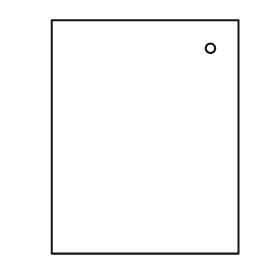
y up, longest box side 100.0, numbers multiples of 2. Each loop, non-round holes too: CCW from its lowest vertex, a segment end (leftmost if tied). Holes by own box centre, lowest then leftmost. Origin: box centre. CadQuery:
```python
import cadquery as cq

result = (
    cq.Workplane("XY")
    .moveTo(-40.0, -50.0)
    .lineTo(40.0, -50.0)
    .lineTo(40.0, 50.0)
    .lineTo(-40.0, 50.0)
    .close()
    .moveTo(28.0, 38.0)
    .circle(2.0)
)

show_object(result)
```